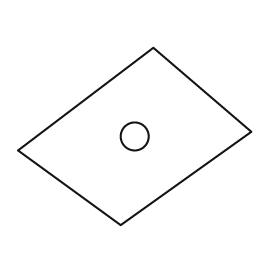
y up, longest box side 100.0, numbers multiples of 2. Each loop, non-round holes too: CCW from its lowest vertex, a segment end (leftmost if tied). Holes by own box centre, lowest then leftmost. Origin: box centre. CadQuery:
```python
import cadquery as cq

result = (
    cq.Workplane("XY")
    .moveTo(-6.0, -38.0)
    .lineTo(50.0, 2.0)
    .lineTo(8.0, 38.0)
    .lineTo(-50.0, -6.0)
    .close()
    .moveTo(0.0, 0.0)
    .circle(6.0)
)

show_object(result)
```